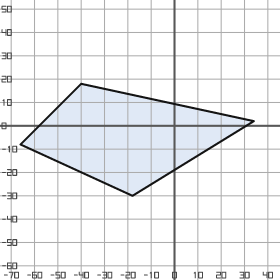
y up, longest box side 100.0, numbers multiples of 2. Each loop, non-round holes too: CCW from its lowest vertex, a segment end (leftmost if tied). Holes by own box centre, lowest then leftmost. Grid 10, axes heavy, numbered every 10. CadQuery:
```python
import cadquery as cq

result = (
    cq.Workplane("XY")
    .moveTo(-18.0, -30.0)
    .lineTo(34.0, 2.0)
    .lineTo(-40.0, 18.0)
    .lineTo(-66.0, -8.0)
    .close()
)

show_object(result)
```